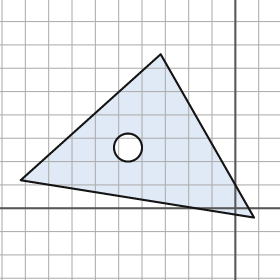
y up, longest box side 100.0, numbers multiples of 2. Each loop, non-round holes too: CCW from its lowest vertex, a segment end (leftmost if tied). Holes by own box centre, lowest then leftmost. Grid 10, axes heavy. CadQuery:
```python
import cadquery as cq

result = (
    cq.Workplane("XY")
    .moveTo(8.0, -4.0)
    .lineTo(-32.0, 66.0)
    .lineTo(-92.0, 12.0)
    .close()
    .moveTo(-46.0, 26.0)
    .circle(6.0)
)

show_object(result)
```